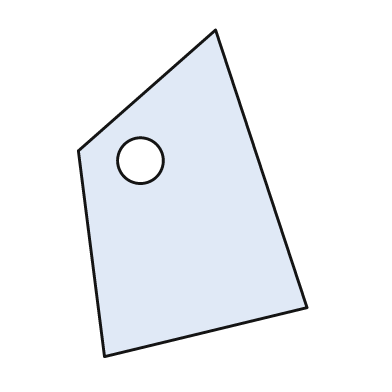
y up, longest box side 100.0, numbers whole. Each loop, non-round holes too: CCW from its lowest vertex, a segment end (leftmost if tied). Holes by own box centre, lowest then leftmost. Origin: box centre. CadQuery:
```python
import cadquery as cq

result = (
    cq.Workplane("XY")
    .moveTo(-27.0, -50.0)
    .lineTo(35.0, -35.0)
    .lineTo(7.0, 50.0)
    .lineTo(-35.0, 13.0)
    .close()
    .moveTo(-16.0, 10.0)
    .circle(7.0)
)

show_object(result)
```